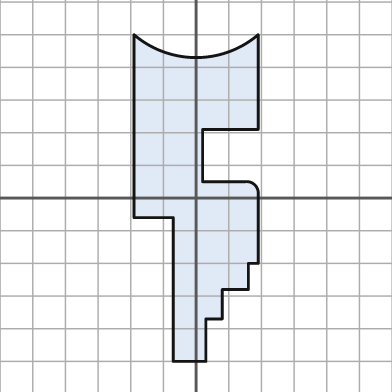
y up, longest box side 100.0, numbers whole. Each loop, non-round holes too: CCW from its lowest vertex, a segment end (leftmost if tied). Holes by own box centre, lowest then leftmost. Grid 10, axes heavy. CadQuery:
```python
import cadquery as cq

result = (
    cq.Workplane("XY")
    .moveTo(-7.0, -50.0)
    .lineTo(3.0, -50.0)
    .lineTo(3.0, -37.0)
    .lineTo(8.0, -37.0)
    .lineTo(8.0, -28.0)
    .lineTo(16.0, -28.0)
    .lineTo(16.0, -20.0)
    .lineTo(19.0, -20.0)
    .lineTo(19.0, 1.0)
    .threePointArc((18.0, 4.0), (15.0, 5.0))
    .lineTo(2.0, 5.0)
    .lineTo(2.0, 21.0)
    .lineTo(19.0, 21.0)
    .lineTo(19.0, 50.0)
    .threePointArc((0.0, 43.0), (-19.0, 50.0))
    .lineTo(-19.0, -6.0)
    .lineTo(-7.0, -6.0)
    .close()
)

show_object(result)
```